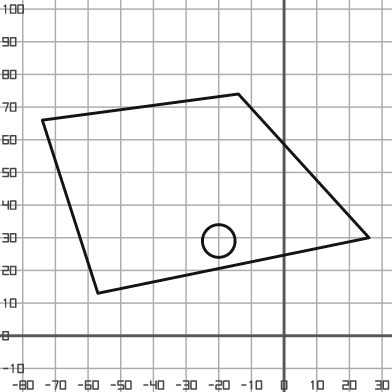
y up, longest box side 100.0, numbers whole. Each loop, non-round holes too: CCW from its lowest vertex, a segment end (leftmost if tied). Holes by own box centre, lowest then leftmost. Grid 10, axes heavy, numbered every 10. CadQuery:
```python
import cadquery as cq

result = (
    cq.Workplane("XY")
    .moveTo(-57.0, 13.0)
    .lineTo(26.0, 30.0)
    .lineTo(-14.0, 74.0)
    .lineTo(-74.0, 66.0)
    .close()
    .moveTo(-20.0, 29.0)
    .circle(5.0)
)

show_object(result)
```